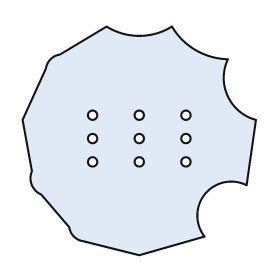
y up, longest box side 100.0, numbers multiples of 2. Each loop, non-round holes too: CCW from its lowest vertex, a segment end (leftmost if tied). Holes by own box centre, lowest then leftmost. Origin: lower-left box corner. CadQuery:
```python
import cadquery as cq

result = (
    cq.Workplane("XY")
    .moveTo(50.0, 0.0)
    .lineTo(78.0, 8.0)
    .threePointArc((78.0, 26.0), (96.0, 30.0))
    .lineTo(100.0, 58.0)
    .threePointArc((88.0, 68.0), (88.0, 84.0))
    .threePointArc((74.0, 88.0), (64.0, 98.0))
    .threePointArc((50.0, 94.0), (36.0, 98.0))
    .lineTo(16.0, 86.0)
    .threePointArc((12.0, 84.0), (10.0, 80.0))
    .lineTo(0.0, 58.0)
    .lineTo(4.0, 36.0)
    .threePointArc((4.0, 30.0), (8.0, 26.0))
    .lineTo(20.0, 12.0)
    .threePointArc((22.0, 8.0), (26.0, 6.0))
    .close()
    .moveTo(30.0, 40.0)
    .circle(2.0)
    .moveTo(50.0, 40.0)
    .circle(2.0)
    .moveTo(70.0, 40.0)
    .circle(2.0)
    .moveTo(30.0, 50.0)
    .circle(2.0)
    .moveTo(50.0, 50.0)
    .circle(2.0)
    .moveTo(70.0, 50.0)
    .circle(2.0)
    .moveTo(30.0, 60.0)
    .circle(2.0)
    .moveTo(50.0, 60.0)
    .circle(2.0)
    .moveTo(70.0, 60.0)
    .circle(2.0)
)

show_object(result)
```